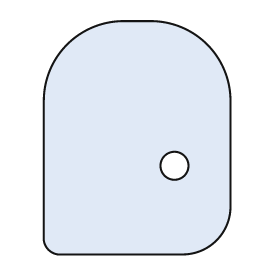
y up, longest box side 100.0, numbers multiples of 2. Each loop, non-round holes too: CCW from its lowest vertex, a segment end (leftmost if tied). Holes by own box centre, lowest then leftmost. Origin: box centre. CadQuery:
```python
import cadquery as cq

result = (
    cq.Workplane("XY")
    .moveTo(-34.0, -50.0)
    .lineTo(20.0, -50.0)
    .threePointArc((34.0, -44.0), (40.0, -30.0))
    .lineTo(40.0, 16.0)
    .threePointArc((30.0, 40.0), (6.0, 50.0))
    .lineTo(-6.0, 50.0)
    .threePointArc((-30.0, 40.0), (-40.0, 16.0))
    .lineTo(-40.0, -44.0)
    .threePointArc((-38.0, -48.0), (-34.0, -50.0))
    .close()
    .moveTo(16.0, -12.0)
    .circle(6.0)
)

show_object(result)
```